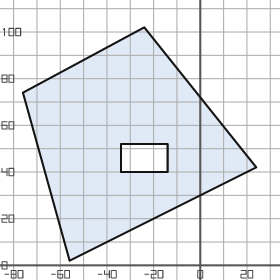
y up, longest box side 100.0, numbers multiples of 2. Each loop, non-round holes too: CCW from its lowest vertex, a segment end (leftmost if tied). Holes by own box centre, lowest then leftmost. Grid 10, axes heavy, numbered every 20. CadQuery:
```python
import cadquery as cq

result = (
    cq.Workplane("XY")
    .moveTo(-56.0, 2.0)
    .lineTo(24.0, 42.0)
    .lineTo(-24.0, 102.0)
    .lineTo(-76.0, 74.0)
    .close()
    .moveTo(-34.0, 40.0)
    .lineTo(-14.0, 40.0)
    .lineTo(-14.0, 52.0)
    .lineTo(-34.0, 52.0)
    .close()
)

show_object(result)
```